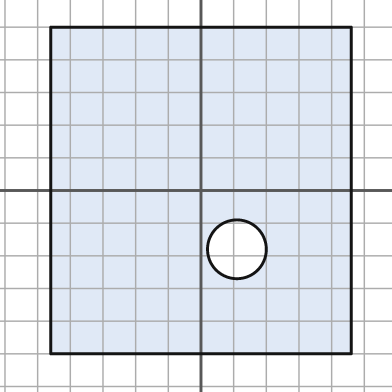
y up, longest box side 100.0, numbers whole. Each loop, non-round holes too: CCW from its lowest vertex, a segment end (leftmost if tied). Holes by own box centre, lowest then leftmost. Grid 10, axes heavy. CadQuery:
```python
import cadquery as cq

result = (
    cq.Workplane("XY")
    .moveTo(-46.0, -50.0)
    .lineTo(46.0, -50.0)
    .lineTo(46.0, 50.0)
    .lineTo(-46.0, 50.0)
    .close()
    .moveTo(11.0, -18.0)
    .circle(9.0)
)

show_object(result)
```